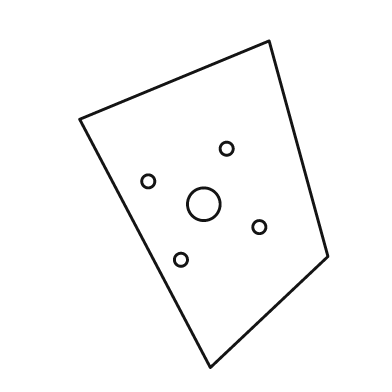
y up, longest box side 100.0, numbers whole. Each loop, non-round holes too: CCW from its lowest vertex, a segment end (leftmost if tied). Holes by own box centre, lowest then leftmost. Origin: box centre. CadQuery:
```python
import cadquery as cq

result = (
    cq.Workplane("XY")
    .moveTo(2.0, -50.0)
    .lineTo(38.0, -16.0)
    .lineTo(20.0, 50.0)
    .lineTo(-38.0, 26.0)
    .close()
    .moveTo(-7.0, -17.0)
    .circle(2.0)
    .moveTo(17.0, -7.0)
    .circle(2.0)
    .moveTo(0.0, 0.0)
    .circle(5.0)
    .moveTo(-17.0, 7.0)
    .circle(2.0)
    .moveTo(7.0, 17.0)
    .circle(2.0)
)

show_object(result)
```